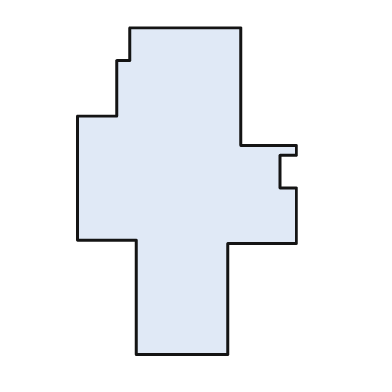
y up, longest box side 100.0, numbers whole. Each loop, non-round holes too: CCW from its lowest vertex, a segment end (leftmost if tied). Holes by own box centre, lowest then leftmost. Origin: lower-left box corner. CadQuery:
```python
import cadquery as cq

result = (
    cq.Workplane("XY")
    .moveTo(18.0, 0.0)
    .lineTo(46.0, 0.0)
    .lineTo(46.0, 34.0)
    .lineTo(67.0, 34.0)
    .lineTo(67.0, 51.0)
    .lineTo(62.0, 51.0)
    .lineTo(62.0, 61.0)
    .lineTo(67.0, 61.0)
    .lineTo(67.0, 64.0)
    .lineTo(50.0, 64.0)
    .lineTo(50.0, 100.0)
    .lineTo(16.0, 100.0)
    .lineTo(16.0, 90.0)
    .lineTo(12.0, 90.0)
    .lineTo(12.0, 73.0)
    .lineTo(0.0, 73.0)
    .lineTo(0.0, 35.0)
    .lineTo(18.0, 35.0)
    .close()
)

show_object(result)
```